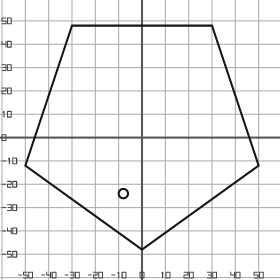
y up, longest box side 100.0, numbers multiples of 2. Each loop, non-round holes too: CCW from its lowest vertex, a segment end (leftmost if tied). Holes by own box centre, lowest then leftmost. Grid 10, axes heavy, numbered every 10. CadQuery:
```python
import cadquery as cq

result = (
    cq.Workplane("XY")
    .moveTo(0.0, -48.0)
    .lineTo(50.0, -12.0)
    .lineTo(30.0, 48.0)
    .lineTo(-30.0, 48.0)
    .lineTo(-50.0, -12.0)
    .close()
    .moveTo(-8.0, -24.0)
    .circle(2.0)
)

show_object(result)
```